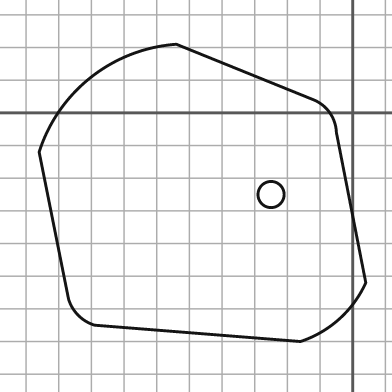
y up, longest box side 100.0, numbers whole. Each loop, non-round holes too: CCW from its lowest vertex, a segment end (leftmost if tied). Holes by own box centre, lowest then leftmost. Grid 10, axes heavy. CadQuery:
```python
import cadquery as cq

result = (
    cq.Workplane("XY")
    .moveTo(-16.0, -70.0)
    .threePointArc((-4.0, -63.0), (4.0, -52.0))
    .lineTo(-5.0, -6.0)
    .threePointArc((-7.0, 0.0), (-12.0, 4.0))
    .lineTo(-54.0, 21.0)
    .threePointArc((-80.0, 11.0), (-96.0, -12.0))
    .lineTo(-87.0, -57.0)
    .threePointArc((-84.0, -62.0), (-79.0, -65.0))
    .close()
    .moveTo(-25.0, -25.0)
    .circle(4.0)
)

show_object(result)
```